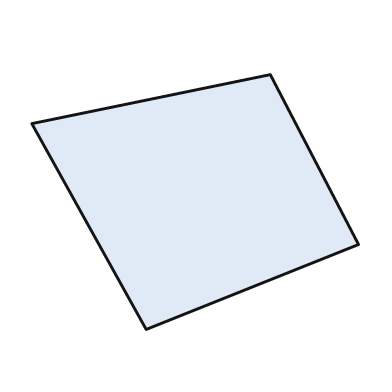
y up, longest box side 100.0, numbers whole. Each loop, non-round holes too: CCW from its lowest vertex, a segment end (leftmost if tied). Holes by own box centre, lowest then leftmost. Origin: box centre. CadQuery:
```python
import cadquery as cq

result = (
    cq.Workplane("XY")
    .moveTo(-15.0, -39.0)
    .lineTo(50.0, -13.0)
    .lineTo(23.0, 39.0)
    .lineTo(-50.0, 24.0)
    .close()
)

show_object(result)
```